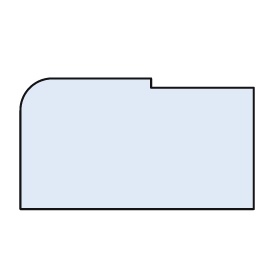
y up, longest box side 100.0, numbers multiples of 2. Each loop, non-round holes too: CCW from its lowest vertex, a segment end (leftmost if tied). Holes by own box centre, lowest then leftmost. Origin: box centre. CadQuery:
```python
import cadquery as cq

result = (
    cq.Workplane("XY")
    .moveTo(-50.0, -28.0)
    .lineTo(50.0, -28.0)
    .lineTo(50.0, 24.0)
    .lineTo(6.0, 24.0)
    .lineTo(6.0, 28.0)
    .lineTo(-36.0, 28.0)
    .threePointArc((-46.0, 24.0), (-50.0, 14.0))
    .close()
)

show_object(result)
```